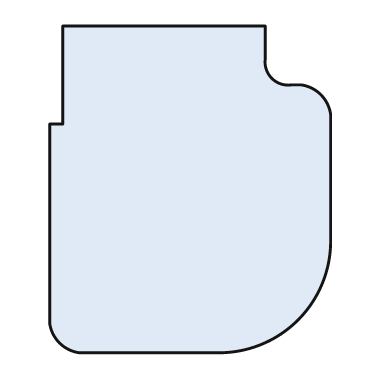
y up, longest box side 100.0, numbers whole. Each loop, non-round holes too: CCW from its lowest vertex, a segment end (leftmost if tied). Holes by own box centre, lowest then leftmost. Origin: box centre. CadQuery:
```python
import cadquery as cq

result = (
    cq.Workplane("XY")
    .moveTo(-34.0, -50.0)
    .lineTo(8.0, -50.0)
    .threePointArc((33.0, -40.0), (43.0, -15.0))
    .lineTo(43.0, 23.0)
    .threePointArc((40.0, 29.0), (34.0, 32.0))
    .lineTo(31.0, 32.0)
    .threePointArc((25.0, 34.0), (23.0, 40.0))
    .lineTo(23.0, 50.0)
    .lineTo(-39.0, 50.0)
    .lineTo(-39.0, 20.0)
    .lineTo(-43.0, 20.0)
    .lineTo(-43.0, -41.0)
    .threePointArc((-40.0, -47.0), (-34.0, -50.0))
    .close()
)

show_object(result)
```